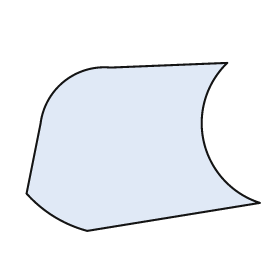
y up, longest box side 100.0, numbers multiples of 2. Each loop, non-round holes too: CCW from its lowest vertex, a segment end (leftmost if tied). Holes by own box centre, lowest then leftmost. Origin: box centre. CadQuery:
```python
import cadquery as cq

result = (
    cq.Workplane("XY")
    .moveTo(-24.0, -36.0)
    .lineTo(50.0, -24.0)
    .threePointArc((26.0, 2.0), (36.0, 36.0))
    .lineTo(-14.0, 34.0)
    .threePointArc((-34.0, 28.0), (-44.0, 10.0))
    .lineTo(-50.0, -20.0)
    .threePointArc((-38.0, -30.0), (-24.0, -36.0))
    .close()
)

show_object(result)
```